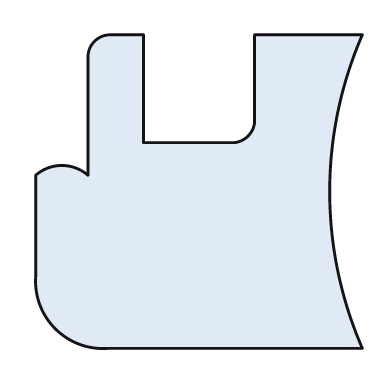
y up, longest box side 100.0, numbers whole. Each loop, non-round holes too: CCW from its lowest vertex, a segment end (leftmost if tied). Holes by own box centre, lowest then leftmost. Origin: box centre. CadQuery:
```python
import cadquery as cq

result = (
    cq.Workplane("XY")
    .moveTo(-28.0, -48.0)
    .lineTo(50.0, -48.0)
    .threePointArc((40.0, 0.0), (50.0, 48.0))
    .lineTo(17.0, 48.0)
    .lineTo(17.0, 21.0)
    .threePointArc((15.0, 17.0), (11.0, 15.0))
    .lineTo(-17.0, 15.0)
    .lineTo(-17.0, 48.0)
    .lineTo(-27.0, 48.0)
    .threePointArc((-32.0, 46.0), (-34.0, 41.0))
    .lineTo(-34.0, 5.0)
    .threePointArc((-42.0, 8.0), (-50.0, 5.0))
    .lineTo(-50.0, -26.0)
    .threePointArc((-44.0, -42.0), (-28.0, -48.0))
    .close()
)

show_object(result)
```